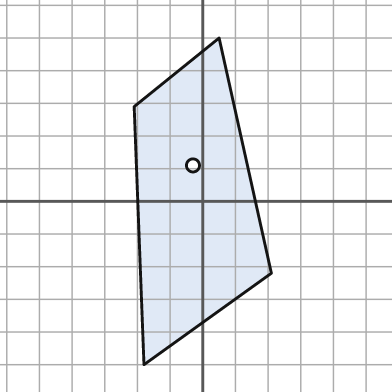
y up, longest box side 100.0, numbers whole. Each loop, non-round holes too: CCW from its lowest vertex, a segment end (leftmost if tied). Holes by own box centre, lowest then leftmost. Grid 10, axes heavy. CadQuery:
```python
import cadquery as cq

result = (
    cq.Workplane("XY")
    .moveTo(-18.0, -50.0)
    .lineTo(21.0, -22.0)
    .lineTo(5.0, 50.0)
    .lineTo(-21.0, 29.0)
    .close()
    .moveTo(-3.0, 11.0)
    .circle(2.0)
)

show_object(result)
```